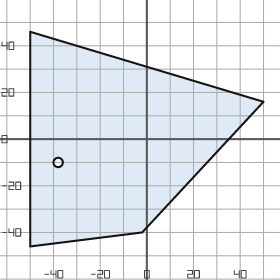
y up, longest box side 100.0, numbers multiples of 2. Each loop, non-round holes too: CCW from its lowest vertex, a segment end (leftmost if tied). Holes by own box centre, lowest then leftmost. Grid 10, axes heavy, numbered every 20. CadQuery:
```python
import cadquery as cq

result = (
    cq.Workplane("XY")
    .moveTo(-50.0, -46.0)
    .lineTo(-2.0, -40.0)
    .lineTo(50.0, 16.0)
    .lineTo(-50.0, 46.0)
    .close()
    .moveTo(-38.0, -10.0)
    .circle(2.0)
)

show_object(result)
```